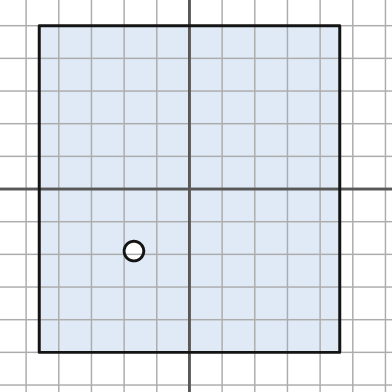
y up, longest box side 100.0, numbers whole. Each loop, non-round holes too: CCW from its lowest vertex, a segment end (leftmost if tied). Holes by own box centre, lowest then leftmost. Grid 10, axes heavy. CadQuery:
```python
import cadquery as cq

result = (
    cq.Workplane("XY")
    .moveTo(-46.0, -50.0)
    .lineTo(46.0, -50.0)
    .lineTo(46.0, 50.0)
    .lineTo(-46.0, 50.0)
    .close()
    .moveTo(-17.0, -19.0)
    .circle(3.0)
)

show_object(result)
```